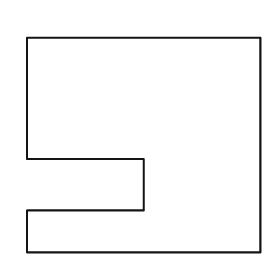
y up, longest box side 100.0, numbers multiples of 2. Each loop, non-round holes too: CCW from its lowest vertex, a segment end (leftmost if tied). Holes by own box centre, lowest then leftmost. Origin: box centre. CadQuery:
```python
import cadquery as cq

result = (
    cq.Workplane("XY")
    .moveTo(-50.0, -46.0)
    .lineTo(50.0, -46.0)
    .lineTo(50.0, 46.0)
    .lineTo(-50.0, 46.0)
    .lineTo(-50.0, -6.0)
    .lineTo(0.0, -6.0)
    .lineTo(0.0, -28.0)
    .lineTo(-50.0, -28.0)
    .close()
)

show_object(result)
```